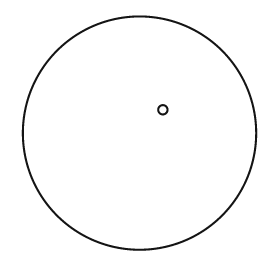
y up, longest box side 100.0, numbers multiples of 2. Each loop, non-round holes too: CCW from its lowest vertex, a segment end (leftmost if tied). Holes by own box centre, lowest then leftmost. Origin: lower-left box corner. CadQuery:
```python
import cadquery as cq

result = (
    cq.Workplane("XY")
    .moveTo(50.0, 50.0)
    .circle(50.0)
    .moveTo(60.0, 60.0)
    .circle(2.0)
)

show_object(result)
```